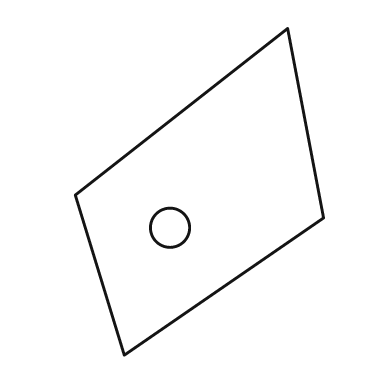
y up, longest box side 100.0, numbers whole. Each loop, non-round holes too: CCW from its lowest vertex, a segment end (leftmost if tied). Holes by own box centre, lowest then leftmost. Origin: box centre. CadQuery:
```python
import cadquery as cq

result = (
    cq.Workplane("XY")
    .moveTo(-23.0, -50.0)
    .lineTo(38.0, -8.0)
    .lineTo(27.0, 50.0)
    .lineTo(-38.0, -1.0)
    .close()
    .moveTo(-9.0, -11.0)
    .circle(6.0)
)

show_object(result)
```